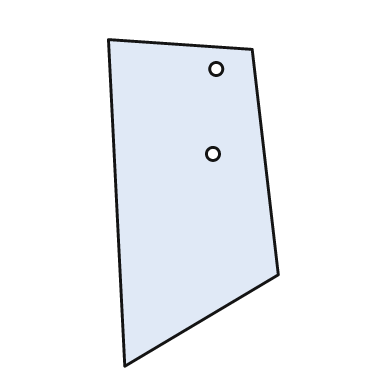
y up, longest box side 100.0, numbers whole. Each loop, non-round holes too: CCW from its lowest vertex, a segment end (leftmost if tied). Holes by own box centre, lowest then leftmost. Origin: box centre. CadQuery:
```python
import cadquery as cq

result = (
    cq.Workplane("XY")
    .moveTo(-21.0, -50.0)
    .lineTo(26.0, -22.0)
    .lineTo(18.0, 47.0)
    .lineTo(-26.0, 50.0)
    .close()
    .moveTo(6.0, 15.0)
    .circle(2.0)
    .moveTo(7.0, 41.0)
    .circle(2.0)
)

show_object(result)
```